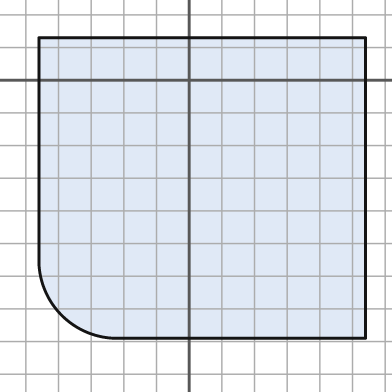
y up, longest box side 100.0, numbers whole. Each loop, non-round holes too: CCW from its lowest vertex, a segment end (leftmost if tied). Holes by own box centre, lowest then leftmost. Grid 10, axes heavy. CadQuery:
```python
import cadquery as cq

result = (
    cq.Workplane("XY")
    .moveTo(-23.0, -79.0)
    .lineTo(54.0, -79.0)
    .lineTo(54.0, 13.0)
    .lineTo(-46.0, 13.0)
    .lineTo(-46.0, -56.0)
    .threePointArc((-39.0, -72.0), (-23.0, -79.0))
    .close()
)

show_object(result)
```